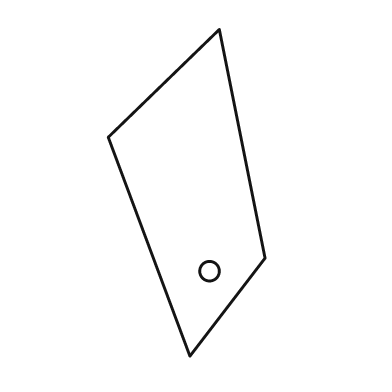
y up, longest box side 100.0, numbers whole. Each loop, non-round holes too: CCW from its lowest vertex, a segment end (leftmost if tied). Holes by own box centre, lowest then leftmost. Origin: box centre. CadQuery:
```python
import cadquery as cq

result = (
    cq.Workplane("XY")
    .moveTo(1.0, -50.0)
    .lineTo(24.0, -20.0)
    .lineTo(10.0, 50.0)
    .lineTo(-24.0, 17.0)
    .close()
    .moveTo(7.0, -24.0)
    .circle(3.0)
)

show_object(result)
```